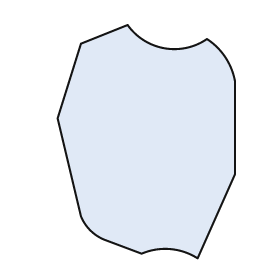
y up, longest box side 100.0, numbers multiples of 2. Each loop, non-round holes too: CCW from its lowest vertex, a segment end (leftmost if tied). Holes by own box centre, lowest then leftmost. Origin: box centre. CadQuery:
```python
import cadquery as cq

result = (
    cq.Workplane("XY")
    .moveTo(22.0, -50.0)
    .lineTo(38.0, -14.0)
    .lineTo(38.0, 26.0)
    .threePointArc((34.0, 36.0), (26.0, 44.0))
    .threePointArc((8.0, 40.0), (-8.0, 50.0))
    .lineTo(-28.0, 42.0)
    .lineTo(-38.0, 10.0)
    .lineTo(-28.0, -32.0)
    .threePointArc((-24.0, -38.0), (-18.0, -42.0))
    .lineTo(-2.0, -48.0)
    .threePointArc((10.0, -46.0), (22.0, -50.0))
    .close()
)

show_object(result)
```